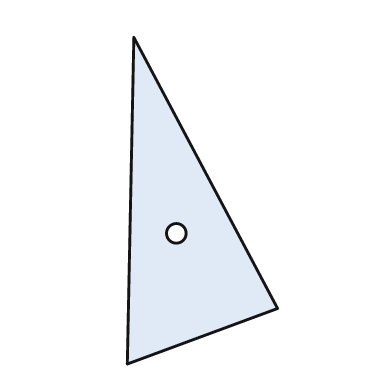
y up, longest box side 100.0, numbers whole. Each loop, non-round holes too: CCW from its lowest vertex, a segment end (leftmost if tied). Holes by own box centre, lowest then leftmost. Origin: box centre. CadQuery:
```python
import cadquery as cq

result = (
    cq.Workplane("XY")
    .moveTo(-23.0, -50.0)
    .lineTo(23.0, -33.0)
    .lineTo(-21.0, 50.0)
    .close()
    .moveTo(-8.0, -10.0)
    .circle(3.0)
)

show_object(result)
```